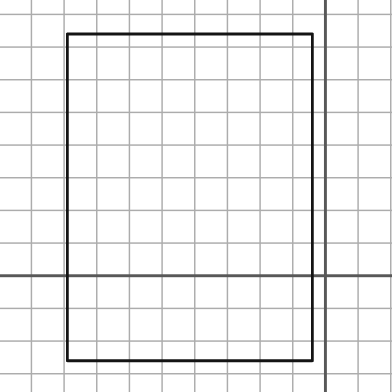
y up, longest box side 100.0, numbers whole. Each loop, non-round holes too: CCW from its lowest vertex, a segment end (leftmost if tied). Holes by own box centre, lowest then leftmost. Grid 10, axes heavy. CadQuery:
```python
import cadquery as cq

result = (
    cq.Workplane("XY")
    .moveTo(-79.0, -26.0)
    .lineTo(-4.0, -26.0)
    .lineTo(-4.0, 74.0)
    .lineTo(-79.0, 74.0)
    .close()
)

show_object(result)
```